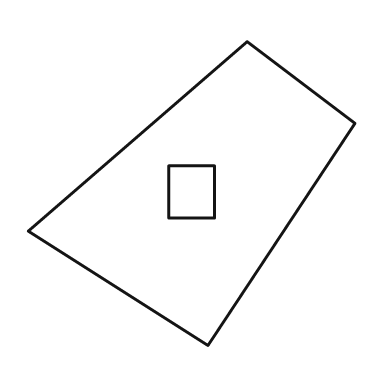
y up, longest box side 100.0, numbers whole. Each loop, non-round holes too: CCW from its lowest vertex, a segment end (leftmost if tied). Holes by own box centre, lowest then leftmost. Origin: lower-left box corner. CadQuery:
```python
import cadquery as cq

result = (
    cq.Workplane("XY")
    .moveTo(55.0, 0.0)
    .lineTo(100.0, 68.0)
    .lineTo(67.0, 93.0)
    .lineTo(0.0, 35.0)
    .close()
    .moveTo(43.0, 39.0)
    .lineTo(57.0, 39.0)
    .lineTo(57.0, 55.0)
    .lineTo(43.0, 55.0)
    .close()
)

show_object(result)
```